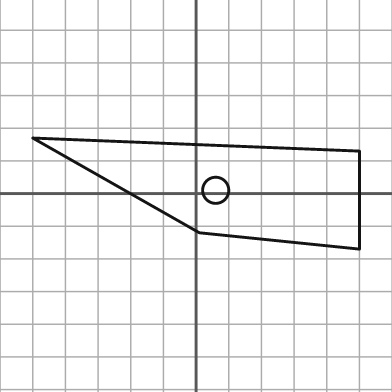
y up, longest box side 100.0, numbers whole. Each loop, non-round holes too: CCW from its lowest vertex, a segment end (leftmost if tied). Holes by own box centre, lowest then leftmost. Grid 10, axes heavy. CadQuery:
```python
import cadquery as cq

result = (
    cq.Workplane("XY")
    .moveTo(50.0, -17.0)
    .lineTo(50.0, 13.0)
    .lineTo(-50.0, 17.0)
    .lineTo(1.0, -12.0)
    .close()
    .moveTo(6.0, 1.0)
    .circle(4.0)
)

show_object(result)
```